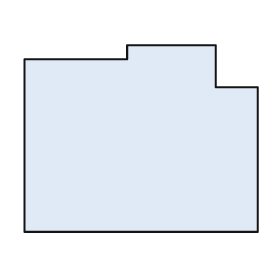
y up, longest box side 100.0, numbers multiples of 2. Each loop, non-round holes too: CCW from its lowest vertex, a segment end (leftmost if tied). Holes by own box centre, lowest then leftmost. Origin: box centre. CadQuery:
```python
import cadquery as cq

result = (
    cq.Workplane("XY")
    .moveTo(-50.0, -40.0)
    .lineTo(50.0, -40.0)
    .lineTo(50.0, 22.0)
    .lineTo(32.0, 22.0)
    .lineTo(32.0, 40.0)
    .lineTo(-6.0, 40.0)
    .lineTo(-6.0, 34.0)
    .lineTo(-50.0, 34.0)
    .close()
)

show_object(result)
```